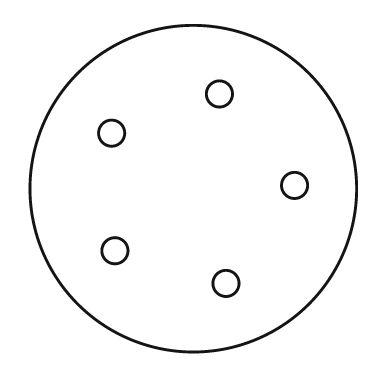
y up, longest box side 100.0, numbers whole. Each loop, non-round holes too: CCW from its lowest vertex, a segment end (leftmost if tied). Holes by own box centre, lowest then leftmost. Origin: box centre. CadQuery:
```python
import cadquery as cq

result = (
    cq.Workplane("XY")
    .moveTo(0.0, 0.0)
    .circle(50.0)
    .moveTo(10.0, -29.0)
    .circle(4.0)
    .moveTo(-24.0, -19.0)
    .circle(4.0)
    .moveTo(31.0, 1.0)
    .circle(4.0)
    .moveTo(-25.0, 17.0)
    .circle(4.0)
    .moveTo(8.0, 29.0)
    .circle(4.0)
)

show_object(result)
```